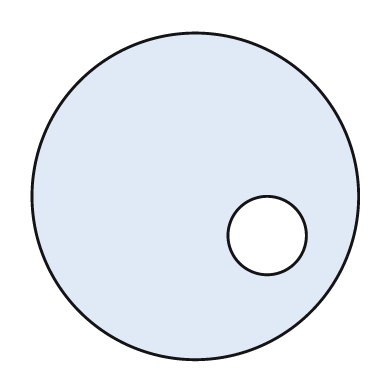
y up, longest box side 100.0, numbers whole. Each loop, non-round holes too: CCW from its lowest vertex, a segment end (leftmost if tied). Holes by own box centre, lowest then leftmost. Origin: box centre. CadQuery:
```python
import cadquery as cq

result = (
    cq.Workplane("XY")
    .moveTo(0.0, 0.0)
    .circle(50.0)
    .moveTo(22.0, -12.0)
    .circle(12.0)
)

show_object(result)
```